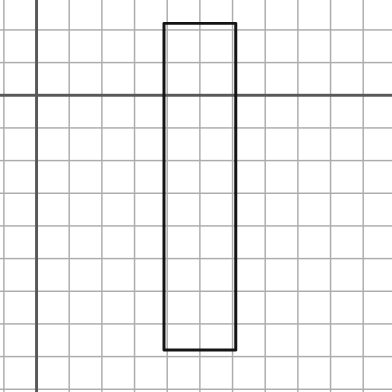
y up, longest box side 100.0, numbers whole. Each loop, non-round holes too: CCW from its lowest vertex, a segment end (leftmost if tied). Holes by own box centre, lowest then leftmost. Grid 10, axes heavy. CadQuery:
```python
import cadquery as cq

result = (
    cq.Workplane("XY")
    .moveTo(39.0, -78.0)
    .lineTo(61.0, -78.0)
    .lineTo(61.0, 22.0)
    .lineTo(39.0, 22.0)
    .close()
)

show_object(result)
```